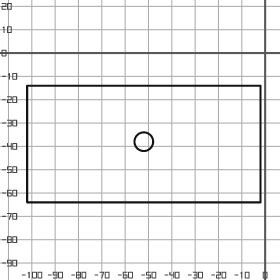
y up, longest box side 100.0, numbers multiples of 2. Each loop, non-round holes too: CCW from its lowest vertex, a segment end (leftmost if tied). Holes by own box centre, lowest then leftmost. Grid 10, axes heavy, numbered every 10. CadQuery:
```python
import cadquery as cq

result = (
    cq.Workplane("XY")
    .moveTo(-102.0, -64.0)
    .lineTo(-2.0, -64.0)
    .lineTo(-2.0, -14.0)
    .lineTo(-102.0, -14.0)
    .close()
    .moveTo(-52.0, -38.0)
    .circle(4.0)
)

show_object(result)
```